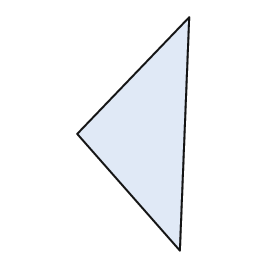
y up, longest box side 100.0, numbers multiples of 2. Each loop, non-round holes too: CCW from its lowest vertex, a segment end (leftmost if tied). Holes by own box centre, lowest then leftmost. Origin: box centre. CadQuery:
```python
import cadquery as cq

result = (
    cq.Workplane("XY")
    .moveTo(20.0, -50.0)
    .lineTo(24.0, 50.0)
    .lineTo(-24.0, 0.0)
    .close()
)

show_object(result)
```